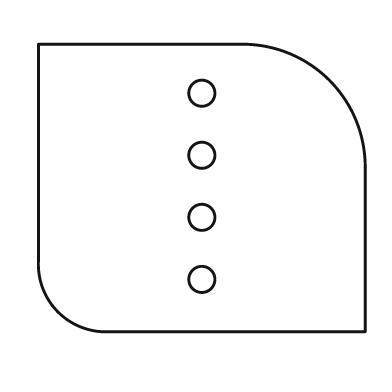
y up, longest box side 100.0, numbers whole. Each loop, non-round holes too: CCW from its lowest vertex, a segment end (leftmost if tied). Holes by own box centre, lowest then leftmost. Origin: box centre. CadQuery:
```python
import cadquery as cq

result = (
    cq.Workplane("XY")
    .moveTo(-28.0, -44.0)
    .lineTo(50.0, -44.0)
    .lineTo(50.0, 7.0)
    .threePointArc((39.0, 33.0), (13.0, 44.0))
    .lineTo(-50.0, 44.0)
    .lineTo(-50.0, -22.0)
    .threePointArc((-44.0, -38.0), (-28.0, -44.0))
    .close()
    .moveTo(0.0, -28.0)
    .circle(4.0)
    .moveTo(0.0, -9.0)
    .circle(4.0)
    .moveTo(0.0, 10.0)
    .circle(4.0)
    .moveTo(0.0, 29.0)
    .circle(4.0)
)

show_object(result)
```